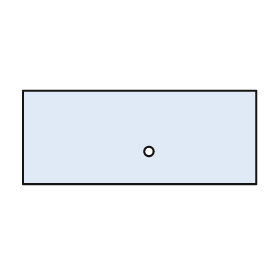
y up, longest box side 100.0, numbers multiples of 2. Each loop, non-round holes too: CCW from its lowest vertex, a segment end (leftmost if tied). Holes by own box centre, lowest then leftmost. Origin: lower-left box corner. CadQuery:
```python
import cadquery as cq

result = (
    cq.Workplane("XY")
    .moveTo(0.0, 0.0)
    .lineTo(100.0, 0.0)
    .lineTo(100.0, 40.0)
    .lineTo(0.0, 40.0)
    .close()
    .moveTo(54.0, 14.0)
    .circle(2.0)
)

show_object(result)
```